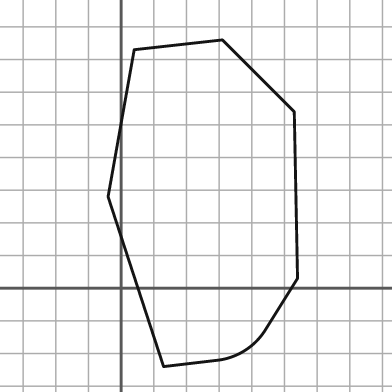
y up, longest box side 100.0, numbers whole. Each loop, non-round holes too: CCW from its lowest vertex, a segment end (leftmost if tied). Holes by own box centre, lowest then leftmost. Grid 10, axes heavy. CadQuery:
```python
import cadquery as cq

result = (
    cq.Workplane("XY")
    .moveTo(13.0, -24.0)
    .lineTo(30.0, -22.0)
    .threePointArc((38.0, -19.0), (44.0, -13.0))
    .lineTo(54.0, 3.0)
    .lineTo(53.0, 54.0)
    .lineTo(31.0, 76.0)
    .lineTo(4.0, 73.0)
    .lineTo(-4.0, 28.0)
    .close()
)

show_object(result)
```